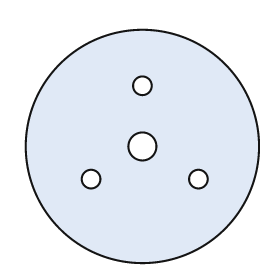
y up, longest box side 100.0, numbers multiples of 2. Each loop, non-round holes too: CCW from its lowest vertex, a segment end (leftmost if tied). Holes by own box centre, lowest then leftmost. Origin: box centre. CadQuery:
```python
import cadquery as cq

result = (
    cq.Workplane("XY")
    .moveTo(0.0, 0.0)
    .circle(50.0)
    .moveTo(-22.0, -14.0)
    .circle(4.0)
    .moveTo(24.0, -14.0)
    .circle(4.0)
    .moveTo(0.0, 0.0)
    .circle(6.0)
    .moveTo(0.0, 26.0)
    .circle(4.0)
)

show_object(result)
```